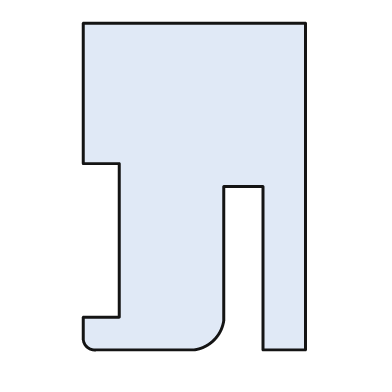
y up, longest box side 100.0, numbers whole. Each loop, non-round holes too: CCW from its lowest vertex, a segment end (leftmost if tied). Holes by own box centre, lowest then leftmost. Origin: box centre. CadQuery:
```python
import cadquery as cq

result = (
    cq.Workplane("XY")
    .moveTo(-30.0, -50.0)
    .lineTo(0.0, -50.0)
    .threePointArc((6.0, -47.0), (9.0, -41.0))
    .lineTo(9.0, 0.0)
    .lineTo(21.0, 0.0)
    .lineTo(21.0, -50.0)
    .lineTo(34.0, -50.0)
    .lineTo(34.0, 50.0)
    .lineTo(-34.0, 50.0)
    .lineTo(-34.0, 7.0)
    .lineTo(-23.0, 7.0)
    .lineTo(-23.0, -40.0)
    .lineTo(-34.0, -40.0)
    .lineTo(-34.0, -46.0)
    .threePointArc((-33.0, -49.0), (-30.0, -50.0))
    .close()
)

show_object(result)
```